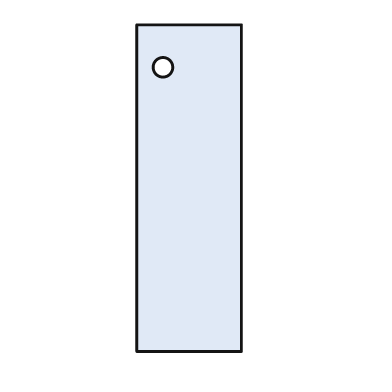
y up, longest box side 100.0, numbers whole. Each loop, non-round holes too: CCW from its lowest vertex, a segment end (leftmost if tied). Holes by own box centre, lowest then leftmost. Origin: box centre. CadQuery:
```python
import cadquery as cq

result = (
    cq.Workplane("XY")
    .moveTo(-16.0, -50.0)
    .lineTo(16.0, -50.0)
    .lineTo(16.0, 50.0)
    .lineTo(-16.0, 50.0)
    .close()
    .moveTo(-8.0, 37.0)
    .circle(3.0)
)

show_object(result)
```